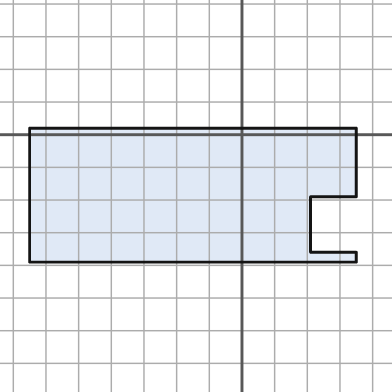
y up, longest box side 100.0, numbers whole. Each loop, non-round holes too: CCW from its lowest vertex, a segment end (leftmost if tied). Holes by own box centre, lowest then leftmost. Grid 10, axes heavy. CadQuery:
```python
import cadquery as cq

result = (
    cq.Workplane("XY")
    .moveTo(-65.0, -39.0)
    .lineTo(35.0, -39.0)
    .lineTo(35.0, -36.0)
    .lineTo(21.0, -36.0)
    .lineTo(21.0, -19.0)
    .lineTo(35.0, -19.0)
    .lineTo(35.0, 2.0)
    .lineTo(-65.0, 2.0)
    .close()
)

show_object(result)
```